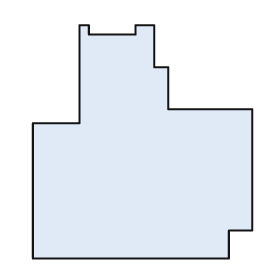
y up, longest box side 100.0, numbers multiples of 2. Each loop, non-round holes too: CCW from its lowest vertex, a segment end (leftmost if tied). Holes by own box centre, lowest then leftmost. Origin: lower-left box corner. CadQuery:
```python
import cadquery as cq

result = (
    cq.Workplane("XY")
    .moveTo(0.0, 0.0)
    .lineTo(84.0, 0.0)
    .lineTo(84.0, 12.0)
    .lineTo(94.0, 12.0)
    .lineTo(94.0, 64.0)
    .lineTo(58.0, 64.0)
    .lineTo(58.0, 82.0)
    .lineTo(52.0, 82.0)
    .lineTo(52.0, 100.0)
    .lineTo(44.0, 100.0)
    .lineTo(44.0, 96.0)
    .lineTo(24.0, 96.0)
    .lineTo(24.0, 100.0)
    .lineTo(20.0, 100.0)
    .lineTo(20.0, 58.0)
    .lineTo(0.0, 58.0)
    .close()
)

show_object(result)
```